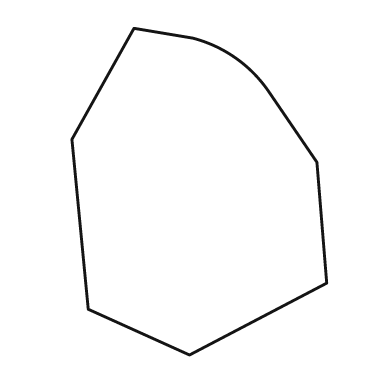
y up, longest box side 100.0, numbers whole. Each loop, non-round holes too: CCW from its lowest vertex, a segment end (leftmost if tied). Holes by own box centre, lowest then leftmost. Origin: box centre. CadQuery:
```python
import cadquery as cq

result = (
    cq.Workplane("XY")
    .moveTo(-3.0, -50.0)
    .lineTo(39.0, -28.0)
    .lineTo(36.0, 9.0)
    .lineTo(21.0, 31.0)
    .threePointArc((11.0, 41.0), (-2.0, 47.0))
    .lineTo(-20.0, 50.0)
    .lineTo(-39.0, 16.0)
    .lineTo(-34.0, -36.0)
    .close()
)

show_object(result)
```